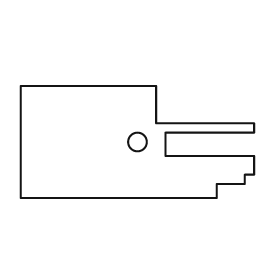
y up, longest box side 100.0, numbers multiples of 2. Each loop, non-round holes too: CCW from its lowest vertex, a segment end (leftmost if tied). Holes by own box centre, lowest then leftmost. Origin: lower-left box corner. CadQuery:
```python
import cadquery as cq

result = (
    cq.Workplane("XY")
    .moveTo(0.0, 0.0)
    .lineTo(84.0, 0.0)
    .lineTo(84.0, 6.0)
    .lineTo(96.0, 6.0)
    .lineTo(96.0, 10.0)
    .lineTo(100.0, 10.0)
    .lineTo(100.0, 18.0)
    .lineTo(62.0, 18.0)
    .lineTo(62.0, 28.0)
    .lineTo(100.0, 28.0)
    .lineTo(100.0, 32.0)
    .lineTo(58.0, 32.0)
    .lineTo(58.0, 48.0)
    .lineTo(0.0, 48.0)
    .close()
    .moveTo(50.0, 24.0)
    .circle(4.0)
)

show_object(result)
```